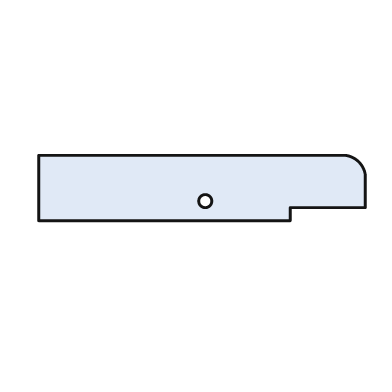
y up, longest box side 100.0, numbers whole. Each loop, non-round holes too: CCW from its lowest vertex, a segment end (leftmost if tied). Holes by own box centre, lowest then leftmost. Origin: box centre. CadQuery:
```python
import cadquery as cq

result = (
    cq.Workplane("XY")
    .moveTo(-50.0, -10.0)
    .lineTo(27.0, -10.0)
    .lineTo(27.0, -6.0)
    .lineTo(50.0, -6.0)
    .lineTo(50.0, 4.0)
    .threePointArc((48.0, 8.0), (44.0, 10.0))
    .lineTo(-50.0, 10.0)
    .close()
    .moveTo(1.0, -4.0)
    .circle(2.0)
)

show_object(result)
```